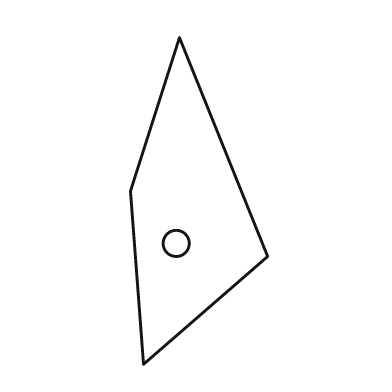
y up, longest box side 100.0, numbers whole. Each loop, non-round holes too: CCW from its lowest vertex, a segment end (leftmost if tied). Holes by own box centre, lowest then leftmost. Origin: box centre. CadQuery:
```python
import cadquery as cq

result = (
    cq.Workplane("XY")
    .moveTo(-17.0, -50.0)
    .lineTo(21.0, -17.0)
    .lineTo(-6.0, 50.0)
    .lineTo(-21.0, 3.0)
    .close()
    .moveTo(-7.0, -13.0)
    .circle(4.0)
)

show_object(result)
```